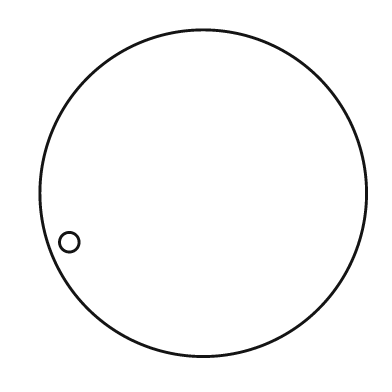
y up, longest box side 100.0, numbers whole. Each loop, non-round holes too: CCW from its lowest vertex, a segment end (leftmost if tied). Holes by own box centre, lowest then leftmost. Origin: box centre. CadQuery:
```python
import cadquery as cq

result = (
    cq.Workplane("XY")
    .moveTo(0.0, 0.0)
    .circle(50.0)
    .moveTo(-41.0, -15.0)
    .circle(3.0)
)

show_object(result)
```